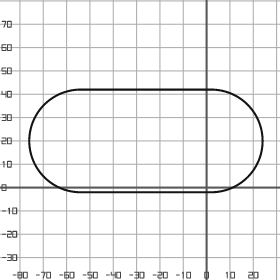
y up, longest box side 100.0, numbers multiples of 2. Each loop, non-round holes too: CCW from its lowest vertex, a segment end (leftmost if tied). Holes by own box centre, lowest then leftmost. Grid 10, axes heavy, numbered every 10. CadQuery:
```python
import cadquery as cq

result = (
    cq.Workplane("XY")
    .moveTo(-54.0, -2.0)
    .lineTo(2.0, -2.0)
    .threePointArc((24.0, 20.0), (2.0, 42.0))
    .lineTo(-54.0, 42.0)
    .threePointArc((-76.0, 20.0), (-54.0, -2.0))
    .close()
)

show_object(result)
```